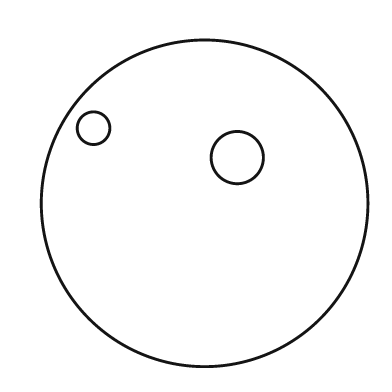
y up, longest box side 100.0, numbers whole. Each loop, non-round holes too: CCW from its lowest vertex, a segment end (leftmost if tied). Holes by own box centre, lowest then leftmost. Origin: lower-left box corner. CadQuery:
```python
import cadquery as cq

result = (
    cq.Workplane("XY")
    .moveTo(50.0, 50.0)
    .circle(50.0)
    .moveTo(60.0, 64.0)
    .circle(8.0)
    .moveTo(16.0, 73.0)
    .circle(5.0)
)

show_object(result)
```